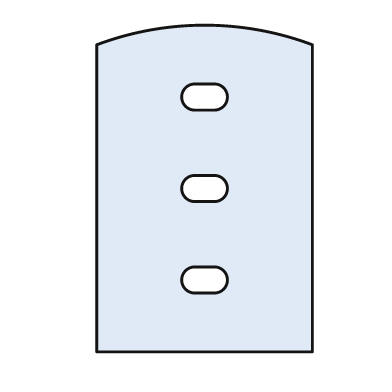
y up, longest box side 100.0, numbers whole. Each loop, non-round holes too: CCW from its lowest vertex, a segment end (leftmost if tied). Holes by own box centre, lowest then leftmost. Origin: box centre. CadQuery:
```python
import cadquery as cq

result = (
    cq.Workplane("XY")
    .moveTo(-33.0, -50.0)
    .lineTo(33.0, -50.0)
    .lineTo(33.0, 44.0)
    .threePointArc((0.0, 50.0), (-33.0, 44.0))
    .close()
    .moveTo(-3.0, -32.0)
    .lineTo(3.0, -32.0)
    .threePointArc((7.0, -28.0), (3.0, -24.0))
    .lineTo(-3.0, -24.0)
    .threePointArc((-7.0, -28.0), (-3.0, -32.0))
    .close()
    .moveTo(-3.0, -4.0)
    .lineTo(3.0, -4.0)
    .threePointArc((7.0, 0.0), (3.0, 4.0))
    .lineTo(-3.0, 4.0)
    .threePointArc((-7.0, 0.0), (-3.0, -4.0))
    .close()
    .moveTo(-3.0, 24.0)
    .lineTo(3.0, 24.0)
    .threePointArc((7.0, 28.0), (3.0, 32.0))
    .lineTo(-3.0, 32.0)
    .threePointArc((-7.0, 28.0), (-3.0, 24.0))
    .close()
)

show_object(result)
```